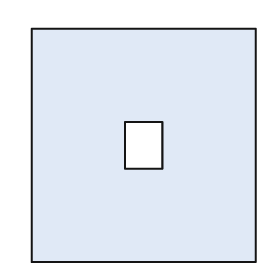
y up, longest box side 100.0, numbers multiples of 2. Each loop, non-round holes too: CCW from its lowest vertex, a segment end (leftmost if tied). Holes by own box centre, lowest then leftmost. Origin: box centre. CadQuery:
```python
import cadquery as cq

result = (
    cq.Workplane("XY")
    .moveTo(-48.0, -50.0)
    .lineTo(48.0, -50.0)
    .lineTo(48.0, 50.0)
    .lineTo(-48.0, 50.0)
    .close()
    .moveTo(-8.0, -10.0)
    .lineTo(8.0, -10.0)
    .lineTo(8.0, 10.0)
    .lineTo(-8.0, 10.0)
    .close()
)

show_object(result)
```